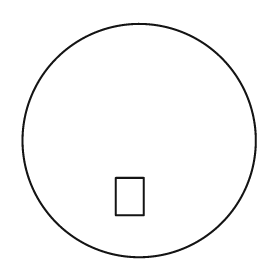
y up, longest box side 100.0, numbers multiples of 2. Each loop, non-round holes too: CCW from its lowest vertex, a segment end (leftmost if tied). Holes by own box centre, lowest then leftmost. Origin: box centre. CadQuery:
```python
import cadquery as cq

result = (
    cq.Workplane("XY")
    .moveTo(0.0, 0.0)
    .circle(50.0)
    .moveTo(-10.0, -32.0)
    .lineTo(2.0, -32.0)
    .lineTo(2.0, -16.0)
    .lineTo(-10.0, -16.0)
    .close()
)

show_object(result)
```